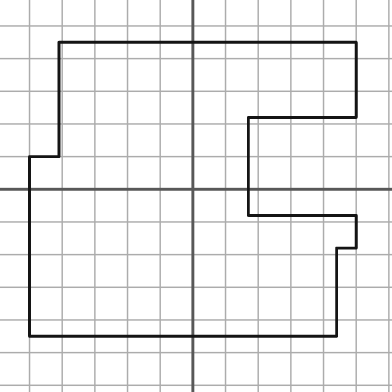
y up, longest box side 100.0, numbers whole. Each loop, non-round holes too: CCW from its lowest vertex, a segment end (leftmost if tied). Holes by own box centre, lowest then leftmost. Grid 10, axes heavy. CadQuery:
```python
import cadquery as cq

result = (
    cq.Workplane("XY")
    .moveTo(-50.0, -45.0)
    .lineTo(44.0, -45.0)
    .lineTo(44.0, -18.0)
    .lineTo(50.0, -18.0)
    .lineTo(50.0, -8.0)
    .lineTo(17.0, -8.0)
    .lineTo(17.0, 22.0)
    .lineTo(50.0, 22.0)
    .lineTo(50.0, 45.0)
    .lineTo(-41.0, 45.0)
    .lineTo(-41.0, 10.0)
    .lineTo(-50.0, 10.0)
    .close()
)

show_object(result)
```